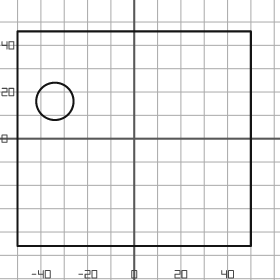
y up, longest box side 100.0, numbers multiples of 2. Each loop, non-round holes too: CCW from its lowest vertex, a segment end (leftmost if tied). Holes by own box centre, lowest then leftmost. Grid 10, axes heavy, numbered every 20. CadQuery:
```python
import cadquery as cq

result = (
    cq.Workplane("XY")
    .moveTo(-50.0, -46.0)
    .lineTo(50.0, -46.0)
    .lineTo(50.0, 46.0)
    .lineTo(-50.0, 46.0)
    .close()
    .moveTo(-34.0, 16.0)
    .circle(8.0)
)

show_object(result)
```